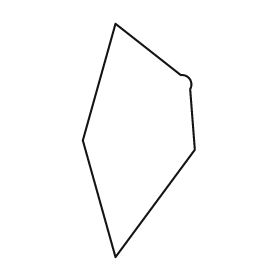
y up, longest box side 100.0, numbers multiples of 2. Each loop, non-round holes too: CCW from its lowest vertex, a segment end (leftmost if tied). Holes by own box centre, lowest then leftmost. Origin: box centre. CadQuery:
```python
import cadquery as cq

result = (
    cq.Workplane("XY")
    .moveTo(-10.0, -50.0)
    .lineTo(24.0, -4.0)
    .lineTo(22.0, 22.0)
    .threePointArc((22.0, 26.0), (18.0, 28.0))
    .lineTo(-10.0, 50.0)
    .lineTo(-24.0, 0.0)
    .close()
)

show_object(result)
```